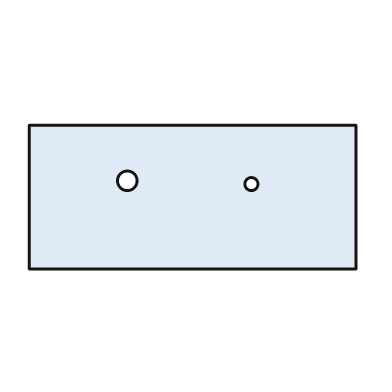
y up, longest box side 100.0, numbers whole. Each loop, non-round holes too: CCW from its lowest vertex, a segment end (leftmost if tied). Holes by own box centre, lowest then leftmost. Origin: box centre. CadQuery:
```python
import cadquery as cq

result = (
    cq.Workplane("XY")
    .moveTo(-50.0, -22.0)
    .lineTo(50.0, -22.0)
    .lineTo(50.0, 22.0)
    .lineTo(-50.0, 22.0)
    .close()
    .moveTo(18.0, 4.0)
    .circle(2.0)
    .moveTo(-20.0, 5.0)
    .circle(3.0)
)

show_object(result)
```